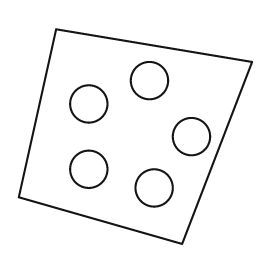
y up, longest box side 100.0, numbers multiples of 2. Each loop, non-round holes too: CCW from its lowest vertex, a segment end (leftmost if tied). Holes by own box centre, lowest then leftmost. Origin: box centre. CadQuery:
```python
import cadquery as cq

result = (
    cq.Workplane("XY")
    .moveTo(20.0, -46.0)
    .lineTo(50.0, 32.0)
    .lineTo(-34.0, 46.0)
    .lineTo(-50.0, -26.0)
    .close()
    .moveTo(8.0, -22.0)
    .circle(8.0)
    .moveTo(-20.0, -14.0)
    .circle(8.0)
    .moveTo(24.0, 0.0)
    .circle(8.0)
    .moveTo(-20.0, 14.0)
    .circle(8.0)
    .moveTo(6.0, 24.0)
    .circle(8.0)
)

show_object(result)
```